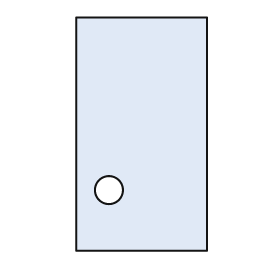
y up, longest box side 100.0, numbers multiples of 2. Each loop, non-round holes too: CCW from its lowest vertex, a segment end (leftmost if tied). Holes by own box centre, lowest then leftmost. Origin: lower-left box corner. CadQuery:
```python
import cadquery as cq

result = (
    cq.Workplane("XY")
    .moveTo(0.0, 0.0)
    .lineTo(56.0, 0.0)
    .lineTo(56.0, 100.0)
    .lineTo(0.0, 100.0)
    .close()
    .moveTo(14.0, 26.0)
    .circle(6.0)
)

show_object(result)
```